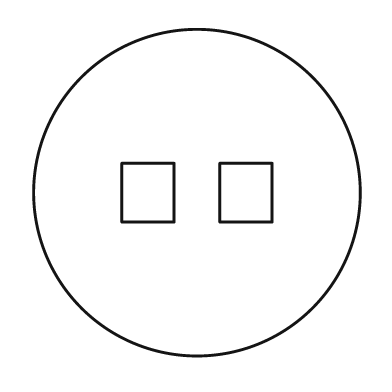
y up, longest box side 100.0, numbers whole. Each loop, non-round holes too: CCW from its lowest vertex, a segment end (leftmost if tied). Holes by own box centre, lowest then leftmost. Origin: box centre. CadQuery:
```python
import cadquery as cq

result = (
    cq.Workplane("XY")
    .moveTo(0.0, 0.0)
    .circle(50.0)
    .moveTo(-23.0, -9.0)
    .lineTo(-7.0, -9.0)
    .lineTo(-7.0, 9.0)
    .lineTo(-23.0, 9.0)
    .close()
    .moveTo(7.0, -9.0)
    .lineTo(23.0, -9.0)
    .lineTo(23.0, 9.0)
    .lineTo(7.0, 9.0)
    .close()
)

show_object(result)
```